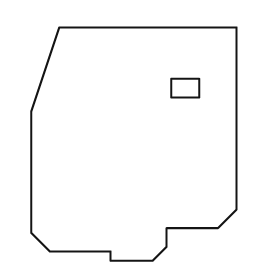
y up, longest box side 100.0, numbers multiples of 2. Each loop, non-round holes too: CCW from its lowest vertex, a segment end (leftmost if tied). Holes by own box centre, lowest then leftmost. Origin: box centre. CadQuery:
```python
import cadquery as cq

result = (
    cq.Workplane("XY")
    .moveTo(-10.0, -50.0)
    .lineTo(8.0, -50.0)
    .lineTo(14.0, -44.0)
    .lineTo(14.0, -36.0)
    .lineTo(36.0, -36.0)
    .lineTo(44.0, -28.0)
    .lineTo(44.0, 50.0)
    .lineTo(-32.0, 50.0)
    .lineTo(-44.0, 14.0)
    .lineTo(-44.0, -38.0)
    .lineTo(-36.0, -46.0)
    .lineTo(-10.0, -46.0)
    .close()
    .moveTo(16.0, 20.0)
    .lineTo(28.0, 20.0)
    .lineTo(28.0, 28.0)
    .lineTo(16.0, 28.0)
    .close()
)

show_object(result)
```